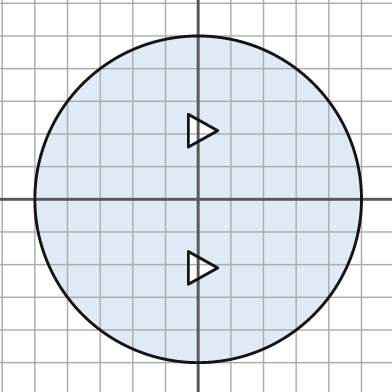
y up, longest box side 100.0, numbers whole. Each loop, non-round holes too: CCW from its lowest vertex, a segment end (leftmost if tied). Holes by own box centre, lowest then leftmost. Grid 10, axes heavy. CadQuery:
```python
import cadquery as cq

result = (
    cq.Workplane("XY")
    .moveTo(0.0, 0.0)
    .circle(50.0)
    .moveTo(-3.0, -26.0)
    .lineTo(6.0, -21.0)
    .lineTo(-3.0, -16.0)
    .close()
    .moveTo(-3.0, 16.0)
    .lineTo(6.0, 21.0)
    .lineTo(-3.0, 26.0)
    .close()
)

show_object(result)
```